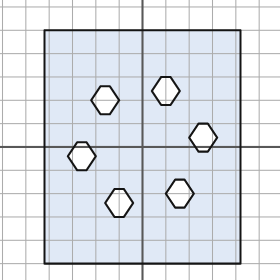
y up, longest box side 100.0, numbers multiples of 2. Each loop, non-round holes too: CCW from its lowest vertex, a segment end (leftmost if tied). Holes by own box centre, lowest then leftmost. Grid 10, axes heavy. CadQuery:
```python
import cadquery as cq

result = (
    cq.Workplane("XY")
    .moveTo(-42.0, -50.0)
    .lineTo(42.0, -50.0)
    .lineTo(42.0, 50.0)
    .lineTo(-42.0, 50.0)
    .close()
    .moveTo(-12.0, -30.0)
    .lineTo(-8.0, -30.0)
    .lineTo(-4.0, -24.0)
    .lineTo(-8.0, -18.0)
    .lineTo(-12.0, -18.0)
    .lineTo(-16.0, -24.0)
    .close()
    .moveTo(14.0, -26.0)
    .lineTo(18.0, -26.0)
    .lineTo(22.0, -20.0)
    .lineTo(18.0, -14.0)
    .lineTo(14.0, -14.0)
    .lineTo(10.0, -20.0)
    .close()
    .moveTo(-28.0, -10.0)
    .lineTo(-24.0, -10.0)
    .lineTo(-20.0, -4.0)
    .lineTo(-24.0, 2.0)
    .lineTo(-28.0, 2.0)
    .lineTo(-32.0, -4.0)
    .close()
    .moveTo(24.0, -2.0)
    .lineTo(28.0, -2.0)
    .lineTo(32.0, 4.0)
    .lineTo(28.0, 10.0)
    .lineTo(24.0, 10.0)
    .lineTo(20.0, 4.0)
    .close()
    .moveTo(-18.0, 14.0)
    .lineTo(-14.0, 14.0)
    .lineTo(-10.0, 20.0)
    .lineTo(-14.0, 26.0)
    .lineTo(-18.0, 26.0)
    .lineTo(-22.0, 20.0)
    .close()
    .moveTo(8.0, 18.0)
    .lineTo(12.0, 18.0)
    .lineTo(16.0, 24.0)
    .lineTo(12.0, 30.0)
    .lineTo(8.0, 30.0)
    .lineTo(4.0, 24.0)
    .close()
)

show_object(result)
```